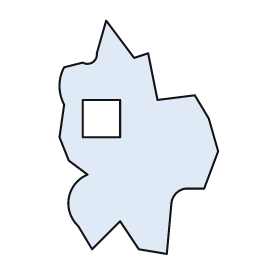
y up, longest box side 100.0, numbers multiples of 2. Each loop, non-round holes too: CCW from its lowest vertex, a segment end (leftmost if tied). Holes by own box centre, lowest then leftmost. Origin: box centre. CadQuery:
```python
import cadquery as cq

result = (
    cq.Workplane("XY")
    .moveTo(12.0, -50.0)
    .lineTo(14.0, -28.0)
    .threePointArc((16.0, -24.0), (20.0, -22.0))
    .lineTo(28.0, -22.0)
    .lineTo(34.0, -6.0)
    .lineTo(30.0, 8.0)
    .lineTo(24.0, 18.0)
    .lineTo(8.0, 16.0)
    .lineTo(4.0, 36.0)
    .lineTo(-2.0, 34.0)
    .lineTo(-14.0, 50.0)
    .lineTo(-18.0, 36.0)
    .threePointArc((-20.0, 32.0), (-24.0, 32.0))
    .lineTo(-32.0, 30.0)
    .threePointArc((-34.0, 22.0), (-32.0, 14.0))
    .lineTo(-34.0, 0.0)
    .lineTo(-30.0, -10.0)
    .lineTo(-22.0, -16.0)
    .threePointArc((-30.0, -26.0), (-26.0, -38.0))
    .lineTo(-20.0, -48.0)
    .lineTo(-8.0, -36.0)
    .lineTo(0.0, -48.0)
    .close()
    .moveTo(-24.0, 0.0)
    .lineTo(-8.0, 0.0)
    .lineTo(-8.0, 16.0)
    .lineTo(-24.0, 16.0)
    .close()
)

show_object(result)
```